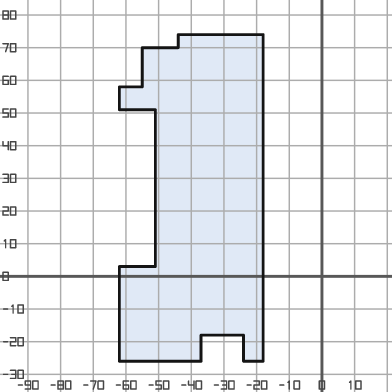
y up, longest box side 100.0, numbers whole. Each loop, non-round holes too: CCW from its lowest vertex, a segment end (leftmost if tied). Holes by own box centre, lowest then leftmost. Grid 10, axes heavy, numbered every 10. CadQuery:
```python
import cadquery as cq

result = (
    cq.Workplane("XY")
    .moveTo(-62.0, -26.0)
    .lineTo(-37.0, -26.0)
    .lineTo(-37.0, -18.0)
    .lineTo(-24.0, -18.0)
    .lineTo(-24.0, -26.0)
    .lineTo(-18.0, -26.0)
    .lineTo(-18.0, 74.0)
    .lineTo(-44.0, 74.0)
    .lineTo(-44.0, 70.0)
    .lineTo(-55.0, 70.0)
    .lineTo(-55.0, 58.0)
    .lineTo(-62.0, 58.0)
    .lineTo(-62.0, 51.0)
    .lineTo(-51.0, 51.0)
    .lineTo(-51.0, 3.0)
    .lineTo(-62.0, 3.0)
    .close()
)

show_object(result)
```